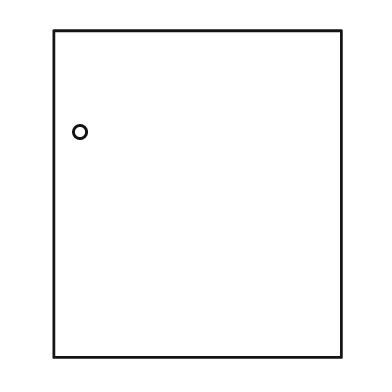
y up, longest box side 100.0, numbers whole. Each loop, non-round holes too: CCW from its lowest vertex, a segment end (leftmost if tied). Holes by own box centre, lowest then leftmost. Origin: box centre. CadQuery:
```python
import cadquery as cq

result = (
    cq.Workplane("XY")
    .moveTo(-44.0, -50.0)
    .lineTo(44.0, -50.0)
    .lineTo(44.0, 50.0)
    .lineTo(-44.0, 50.0)
    .close()
    .moveTo(-36.0, 19.0)
    .circle(2.0)
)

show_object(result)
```